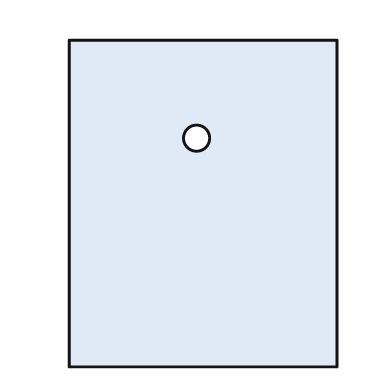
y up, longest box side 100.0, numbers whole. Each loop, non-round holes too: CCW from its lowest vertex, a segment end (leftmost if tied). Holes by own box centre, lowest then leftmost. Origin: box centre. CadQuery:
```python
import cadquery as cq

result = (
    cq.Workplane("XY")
    .moveTo(-41.0, -50.0)
    .lineTo(41.0, -50.0)
    .lineTo(41.0, 50.0)
    .lineTo(-41.0, 50.0)
    .close()
    .moveTo(-2.0, 20.0)
    .circle(4.0)
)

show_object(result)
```